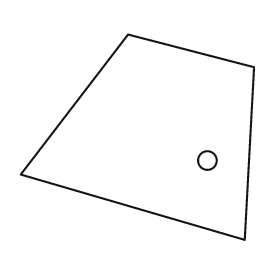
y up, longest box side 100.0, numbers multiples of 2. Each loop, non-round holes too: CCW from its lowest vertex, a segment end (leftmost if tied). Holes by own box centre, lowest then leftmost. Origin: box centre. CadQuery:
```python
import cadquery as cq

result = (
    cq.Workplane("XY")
    .moveTo(46.0, -44.0)
    .lineTo(50.0, 30.0)
    .lineTo(-4.0, 44.0)
    .lineTo(-50.0, -16.0)
    .close()
    .moveTo(30.0, -10.0)
    .circle(4.0)
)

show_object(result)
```